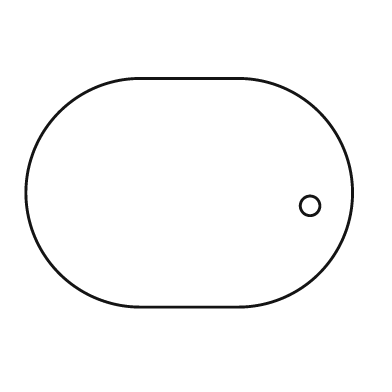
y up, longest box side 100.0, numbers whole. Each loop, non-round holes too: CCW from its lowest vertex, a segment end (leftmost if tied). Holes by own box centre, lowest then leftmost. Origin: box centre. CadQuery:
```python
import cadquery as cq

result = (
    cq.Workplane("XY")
    .moveTo(-15.0, -35.0)
    .lineTo(15.0, -35.0)
    .threePointArc((50.0, 0.0), (15.0, 35.0))
    .lineTo(-15.0, 35.0)
    .threePointArc((-50.0, 0.0), (-15.0, -35.0))
    .close()
    .moveTo(37.0, -4.0)
    .circle(3.0)
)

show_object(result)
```